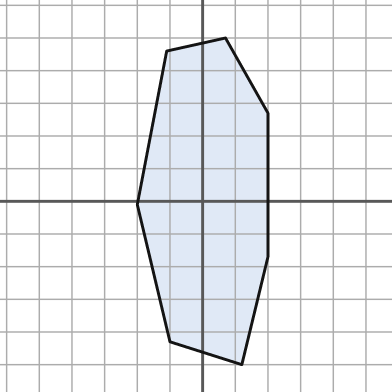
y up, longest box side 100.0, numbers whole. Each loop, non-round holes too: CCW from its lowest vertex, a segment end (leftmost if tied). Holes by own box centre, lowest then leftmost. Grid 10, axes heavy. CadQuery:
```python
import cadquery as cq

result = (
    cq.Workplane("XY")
    .moveTo(12.0, -50.0)
    .lineTo(20.0, -17.0)
    .lineTo(20.0, 27.0)
    .lineTo(7.0, 50.0)
    .lineTo(-11.0, 46.0)
    .lineTo(-20.0, -1.0)
    .lineTo(-10.0, -43.0)
    .close()
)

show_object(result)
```